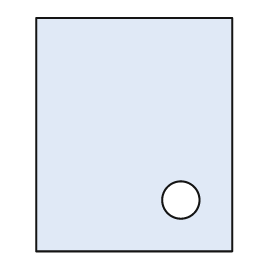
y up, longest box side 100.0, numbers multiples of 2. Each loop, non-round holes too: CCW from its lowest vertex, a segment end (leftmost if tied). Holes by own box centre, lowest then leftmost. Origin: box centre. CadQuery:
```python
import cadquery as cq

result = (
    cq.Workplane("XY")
    .moveTo(-42.0, -50.0)
    .lineTo(42.0, -50.0)
    .lineTo(42.0, 50.0)
    .lineTo(-42.0, 50.0)
    .close()
    .moveTo(20.0, -28.0)
    .circle(8.0)
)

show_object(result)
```